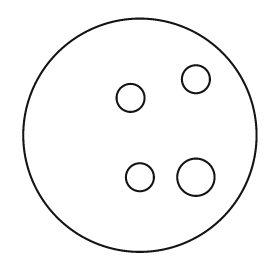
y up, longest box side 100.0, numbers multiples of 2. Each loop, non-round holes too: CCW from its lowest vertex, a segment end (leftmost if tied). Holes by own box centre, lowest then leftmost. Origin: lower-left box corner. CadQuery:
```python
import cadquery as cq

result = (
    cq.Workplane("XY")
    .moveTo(50.0, 50.0)
    .circle(50.0)
    .moveTo(50.0, 32.0)
    .circle(6.0)
    .moveTo(74.0, 32.0)
    .circle(8.0)
    .moveTo(46.0, 66.0)
    .circle(6.0)
    .moveTo(74.0, 74.0)
    .circle(6.0)
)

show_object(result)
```